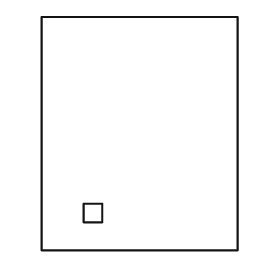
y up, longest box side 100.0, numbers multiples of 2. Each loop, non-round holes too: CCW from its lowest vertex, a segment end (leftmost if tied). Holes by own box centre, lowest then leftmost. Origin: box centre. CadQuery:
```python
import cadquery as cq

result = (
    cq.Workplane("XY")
    .moveTo(-42.0, -50.0)
    .lineTo(42.0, -50.0)
    .lineTo(42.0, 50.0)
    .lineTo(-42.0, 50.0)
    .close()
    .moveTo(-24.0, -38.0)
    .lineTo(-16.0, -38.0)
    .lineTo(-16.0, -30.0)
    .lineTo(-24.0, -30.0)
    .close()
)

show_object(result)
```